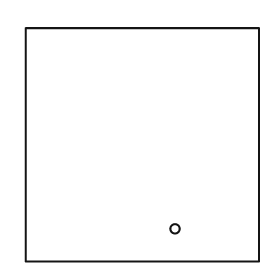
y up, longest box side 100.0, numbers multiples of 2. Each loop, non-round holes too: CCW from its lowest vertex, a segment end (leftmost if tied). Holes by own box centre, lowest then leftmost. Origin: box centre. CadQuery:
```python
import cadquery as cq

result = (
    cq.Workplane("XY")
    .moveTo(-50.0, -50.0)
    .lineTo(50.0, -50.0)
    .lineTo(50.0, 50.0)
    .lineTo(-50.0, 50.0)
    .close()
    .moveTo(14.0, -36.0)
    .circle(2.0)
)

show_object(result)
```